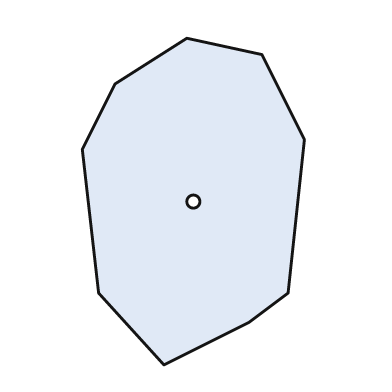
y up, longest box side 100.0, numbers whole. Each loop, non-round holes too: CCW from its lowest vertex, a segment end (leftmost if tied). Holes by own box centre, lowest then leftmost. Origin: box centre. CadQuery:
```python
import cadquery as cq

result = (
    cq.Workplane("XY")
    .moveTo(-9.0, -50.0)
    .lineTo(17.0, -37.0)
    .lineTo(29.0, -28.0)
    .lineTo(34.0, 19.0)
    .lineTo(21.0, 45.0)
    .lineTo(-2.0, 50.0)
    .lineTo(-24.0, 36.0)
    .lineTo(-34.0, 16.0)
    .lineTo(-29.0, -28.0)
    .close()
    .moveTo(0.0, 0.0)
    .circle(2.0)
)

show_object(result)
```